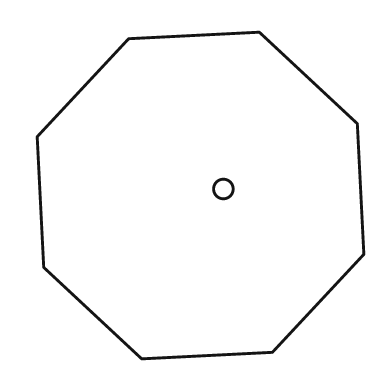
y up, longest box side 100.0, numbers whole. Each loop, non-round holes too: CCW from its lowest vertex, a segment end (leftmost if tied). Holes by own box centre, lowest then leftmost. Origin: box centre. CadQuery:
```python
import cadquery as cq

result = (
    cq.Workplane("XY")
    .moveTo(-18.0, -50.0)
    .lineTo(22.0, -48.0)
    .lineTo(50.0, -18.0)
    .lineTo(48.0, 22.0)
    .lineTo(18.0, 50.0)
    .lineTo(-22.0, 48.0)
    .lineTo(-50.0, 18.0)
    .lineTo(-48.0, -22.0)
    .close()
    .moveTo(7.0, 2.0)
    .circle(3.0)
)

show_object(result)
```